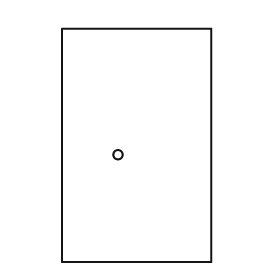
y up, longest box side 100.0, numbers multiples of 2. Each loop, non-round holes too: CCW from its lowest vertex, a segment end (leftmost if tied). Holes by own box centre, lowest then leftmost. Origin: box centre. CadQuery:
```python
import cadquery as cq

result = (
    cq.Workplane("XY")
    .moveTo(-32.0, -50.0)
    .lineTo(32.0, -50.0)
    .lineTo(32.0, 50.0)
    .lineTo(-32.0, 50.0)
    .close()
    .moveTo(-8.0, -4.0)
    .circle(2.0)
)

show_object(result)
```